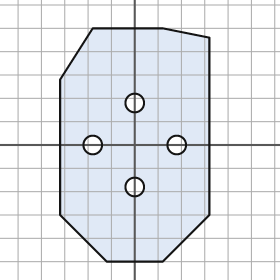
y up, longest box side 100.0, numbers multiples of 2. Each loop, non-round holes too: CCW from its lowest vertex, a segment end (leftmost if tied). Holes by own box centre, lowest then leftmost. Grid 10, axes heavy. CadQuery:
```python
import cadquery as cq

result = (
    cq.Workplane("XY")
    .moveTo(-12.0, -50.0)
    .lineTo(12.0, -50.0)
    .lineTo(32.0, -30.0)
    .lineTo(32.0, 46.0)
    .lineTo(12.0, 50.0)
    .lineTo(-18.0, 50.0)
    .lineTo(-32.0, 28.0)
    .lineTo(-32.0, -30.0)
    .close()
    .moveTo(0.0, -18.0)
    .circle(4.0)
    .moveTo(-18.0, 0.0)
    .circle(4.0)
    .moveTo(18.0, 0.0)
    .circle(4.0)
    .moveTo(0.0, 18.0)
    .circle(4.0)
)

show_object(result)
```